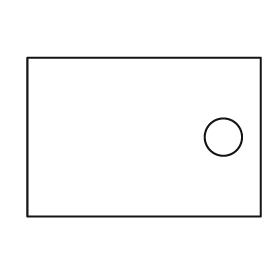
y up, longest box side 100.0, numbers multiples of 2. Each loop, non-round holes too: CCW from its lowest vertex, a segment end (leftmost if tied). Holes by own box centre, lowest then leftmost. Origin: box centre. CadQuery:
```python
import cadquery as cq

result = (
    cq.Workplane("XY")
    .moveTo(-50.0, -34.0)
    .lineTo(50.0, -34.0)
    .lineTo(50.0, 34.0)
    .lineTo(-50.0, 34.0)
    .close()
    .moveTo(34.0, 0.0)
    .circle(8.0)
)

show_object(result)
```